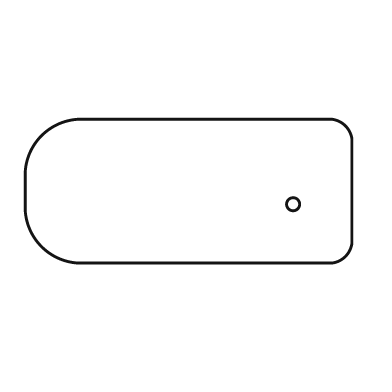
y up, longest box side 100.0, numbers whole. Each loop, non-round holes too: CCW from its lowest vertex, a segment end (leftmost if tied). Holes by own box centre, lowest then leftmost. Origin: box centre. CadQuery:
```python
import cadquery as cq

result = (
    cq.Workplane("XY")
    .moveTo(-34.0, -22.0)
    .lineTo(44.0, -22.0)
    .threePointArc((48.0, -20.0), (50.0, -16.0))
    .lineTo(50.0, 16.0)
    .threePointArc((48.0, 20.0), (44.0, 22.0))
    .lineTo(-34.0, 22.0)
    .threePointArc((-45.0, 17.0), (-50.0, 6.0))
    .lineTo(-50.0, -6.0)
    .threePointArc((-45.0, -17.0), (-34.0, -22.0))
    .close()
    .moveTo(32.0, -4.0)
    .circle(2.0)
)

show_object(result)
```